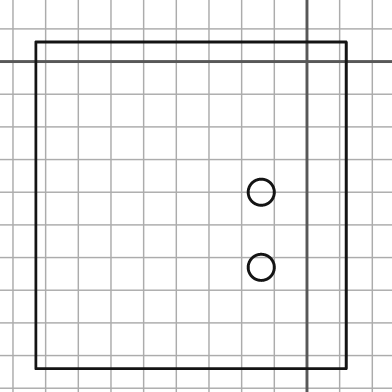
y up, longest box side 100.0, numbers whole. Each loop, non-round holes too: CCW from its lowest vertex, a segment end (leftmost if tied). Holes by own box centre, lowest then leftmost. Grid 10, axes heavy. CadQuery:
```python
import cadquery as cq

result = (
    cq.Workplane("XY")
    .moveTo(-83.0, -94.0)
    .lineTo(12.0, -94.0)
    .lineTo(12.0, 6.0)
    .lineTo(-83.0, 6.0)
    .close()
    .moveTo(-14.0, -63.0)
    .circle(4.0)
    .moveTo(-14.0, -40.0)
    .circle(4.0)
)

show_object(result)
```